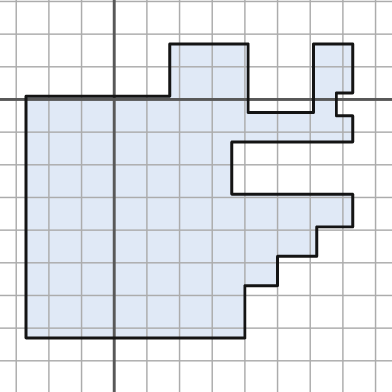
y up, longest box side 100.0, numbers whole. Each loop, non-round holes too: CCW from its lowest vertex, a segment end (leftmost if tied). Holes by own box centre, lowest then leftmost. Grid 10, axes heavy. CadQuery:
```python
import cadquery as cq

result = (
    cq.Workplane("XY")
    .moveTo(-27.0, -73.0)
    .lineTo(40.0, -73.0)
    .lineTo(40.0, -57.0)
    .lineTo(50.0, -57.0)
    .lineTo(50.0, -48.0)
    .lineTo(62.0, -48.0)
    .lineTo(62.0, -39.0)
    .lineTo(73.0, -39.0)
    .lineTo(73.0, -29.0)
    .lineTo(36.0, -29.0)
    .lineTo(36.0, -13.0)
    .lineTo(73.0, -13.0)
    .lineTo(73.0, -5.0)
    .lineTo(68.0, -5.0)
    .lineTo(68.0, 2.0)
    .lineTo(73.0, 2.0)
    .lineTo(73.0, 17.0)
    .lineTo(61.0, 17.0)
    .lineTo(61.0, -4.0)
    .lineTo(41.0, -4.0)
    .lineTo(41.0, 17.0)
    .lineTo(17.0, 17.0)
    .lineTo(17.0, 1.0)
    .lineTo(-27.0, 1.0)
    .close()
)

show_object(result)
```